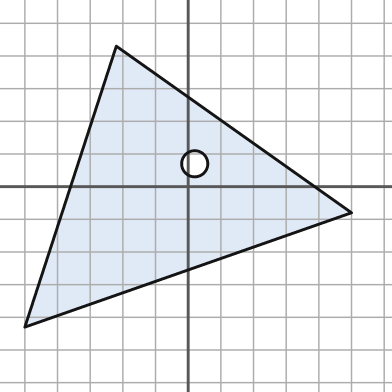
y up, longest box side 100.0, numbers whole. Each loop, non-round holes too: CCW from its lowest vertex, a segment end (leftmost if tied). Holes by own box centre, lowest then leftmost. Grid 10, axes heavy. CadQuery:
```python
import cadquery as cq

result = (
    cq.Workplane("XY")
    .moveTo(-50.0, -43.0)
    .lineTo(50.0, -8.0)
    .lineTo(-22.0, 43.0)
    .close()
    .moveTo(2.0, 7.0)
    .circle(4.0)
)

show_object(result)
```